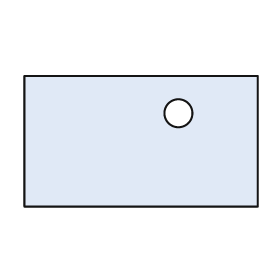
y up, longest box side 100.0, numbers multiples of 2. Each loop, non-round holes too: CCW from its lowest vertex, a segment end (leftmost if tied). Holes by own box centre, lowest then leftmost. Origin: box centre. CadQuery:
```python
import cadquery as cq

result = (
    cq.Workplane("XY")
    .moveTo(-50.0, -28.0)
    .lineTo(50.0, -28.0)
    .lineTo(50.0, 28.0)
    .lineTo(-50.0, 28.0)
    .close()
    .moveTo(16.0, 12.0)
    .circle(6.0)
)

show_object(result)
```